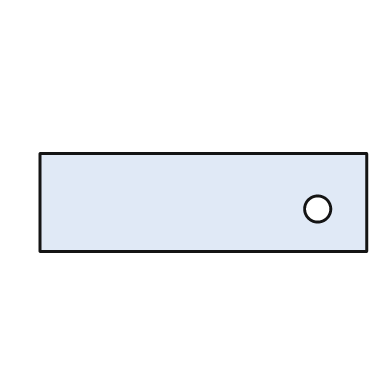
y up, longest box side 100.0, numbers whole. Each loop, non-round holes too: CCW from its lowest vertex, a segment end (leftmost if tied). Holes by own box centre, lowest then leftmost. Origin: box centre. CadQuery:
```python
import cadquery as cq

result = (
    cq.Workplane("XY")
    .moveTo(-50.0, -15.0)
    .lineTo(50.0, -15.0)
    .lineTo(50.0, 15.0)
    .lineTo(-50.0, 15.0)
    .close()
    .moveTo(35.0, -2.0)
    .circle(4.0)
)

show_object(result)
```